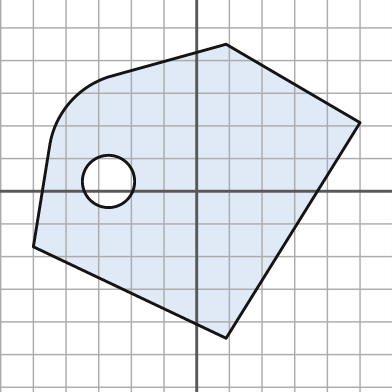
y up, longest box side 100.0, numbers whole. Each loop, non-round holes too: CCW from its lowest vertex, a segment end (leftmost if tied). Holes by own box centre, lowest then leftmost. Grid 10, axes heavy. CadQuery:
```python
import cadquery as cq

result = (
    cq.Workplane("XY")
    .moveTo(9.0, -45.0)
    .lineTo(50.0, 21.0)
    .lineTo(9.0, 45.0)
    .lineTo(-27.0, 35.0)
    .threePointArc((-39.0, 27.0), (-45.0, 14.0))
    .lineTo(-50.0, -17.0)
    .close()
    .moveTo(-27.0, 3.0)
    .circle(8.0)
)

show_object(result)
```